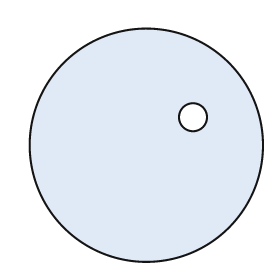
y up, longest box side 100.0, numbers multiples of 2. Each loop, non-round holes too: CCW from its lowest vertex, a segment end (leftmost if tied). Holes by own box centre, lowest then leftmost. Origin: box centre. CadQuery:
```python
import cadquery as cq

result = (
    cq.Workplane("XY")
    .moveTo(0.0, 0.0)
    .circle(50.0)
    .moveTo(20.0, 12.0)
    .circle(6.0)
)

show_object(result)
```